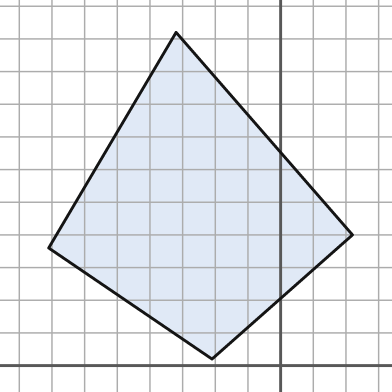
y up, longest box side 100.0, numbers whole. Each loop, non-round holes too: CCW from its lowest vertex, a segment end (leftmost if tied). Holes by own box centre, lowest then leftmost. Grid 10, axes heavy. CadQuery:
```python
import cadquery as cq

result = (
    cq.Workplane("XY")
    .moveTo(-21.0, 2.0)
    .lineTo(22.0, 40.0)
    .lineTo(-32.0, 102.0)
    .lineTo(-71.0, 36.0)
    .close()
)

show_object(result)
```